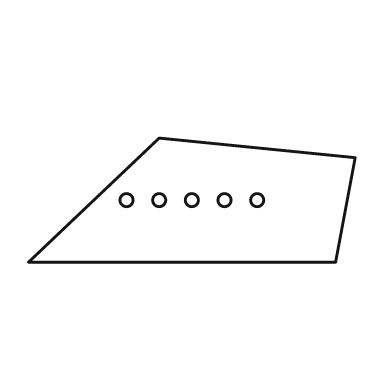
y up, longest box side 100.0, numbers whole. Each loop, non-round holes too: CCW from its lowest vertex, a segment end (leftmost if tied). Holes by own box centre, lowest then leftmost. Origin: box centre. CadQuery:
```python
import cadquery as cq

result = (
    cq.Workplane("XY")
    .moveTo(-50.0, -19.0)
    .lineTo(44.0, -19.0)
    .lineTo(50.0, 13.0)
    .lineTo(-10.0, 19.0)
    .close()
    .moveTo(-20.0, 0.0)
    .circle(2.0)
    .moveTo(-10.0, 0.0)
    .circle(2.0)
    .moveTo(0.0, 0.0)
    .circle(2.0)
    .moveTo(10.0, 0.0)
    .circle(2.0)
    .moveTo(20.0, 0.0)
    .circle(2.0)
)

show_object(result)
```